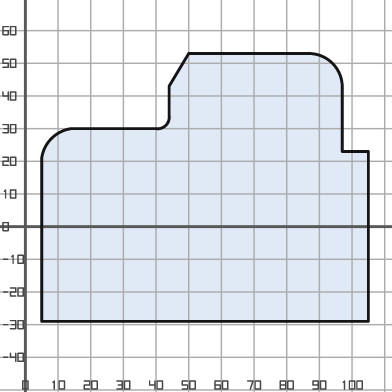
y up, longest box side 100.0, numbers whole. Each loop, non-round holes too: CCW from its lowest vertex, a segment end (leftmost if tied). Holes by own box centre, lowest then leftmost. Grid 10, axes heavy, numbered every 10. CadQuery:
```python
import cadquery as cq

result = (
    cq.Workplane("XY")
    .moveTo(5.0, -29.0)
    .lineTo(105.0, -29.0)
    .lineTo(105.0, 23.0)
    .lineTo(97.0, 23.0)
    .lineTo(97.0, 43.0)
    .threePointArc((94.0, 50.0), (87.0, 53.0))
    .lineTo(50.0, 53.0)
    .lineTo(44.0, 43.0)
    .lineTo(44.0, 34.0)
    .threePointArc((43.0, 31.0), (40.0, 30.0))
    .lineTo(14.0, 30.0)
    .threePointArc((8.0, 27.0), (5.0, 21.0))
    .close()
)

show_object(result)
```